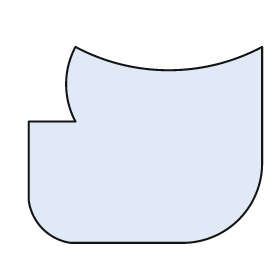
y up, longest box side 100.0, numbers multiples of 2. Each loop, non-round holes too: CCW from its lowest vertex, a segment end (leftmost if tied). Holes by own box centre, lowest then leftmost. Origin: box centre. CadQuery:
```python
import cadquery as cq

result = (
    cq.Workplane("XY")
    .moveTo(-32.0, -42.0)
    .lineTo(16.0, -42.0)
    .threePointArc((40.0, -32.0), (50.0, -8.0))
    .lineTo(50.0, 42.0)
    .threePointArc((10.0, 32.0), (-30.0, 42.0))
    .threePointArc((-34.0, 26.0), (-30.0, 10.0))
    .lineTo(-50.0, 10.0)
    .lineTo(-50.0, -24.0)
    .threePointArc((-44.0, -36.0), (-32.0, -42.0))
    .close()
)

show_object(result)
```